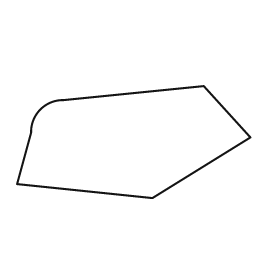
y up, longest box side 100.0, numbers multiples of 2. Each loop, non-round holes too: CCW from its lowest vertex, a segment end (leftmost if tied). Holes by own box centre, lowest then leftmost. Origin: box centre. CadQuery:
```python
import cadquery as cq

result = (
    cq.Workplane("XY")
    .moveTo(8.0, -24.0)
    .lineTo(50.0, 2.0)
    .lineTo(30.0, 24.0)
    .lineTo(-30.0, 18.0)
    .threePointArc((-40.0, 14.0), (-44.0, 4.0))
    .lineTo(-50.0, -18.0)
    .close()
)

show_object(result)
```